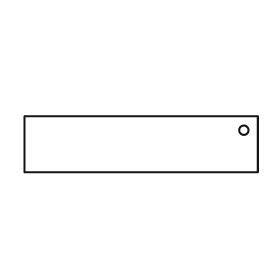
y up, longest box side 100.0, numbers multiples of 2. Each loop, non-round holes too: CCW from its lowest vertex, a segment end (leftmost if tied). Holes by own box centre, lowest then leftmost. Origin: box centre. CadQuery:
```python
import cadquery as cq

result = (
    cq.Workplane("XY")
    .moveTo(-50.0, -12.0)
    .lineTo(50.0, -12.0)
    .lineTo(50.0, 12.0)
    .lineTo(-50.0, 12.0)
    .close()
    .moveTo(44.0, 6.0)
    .circle(2.0)
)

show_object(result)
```